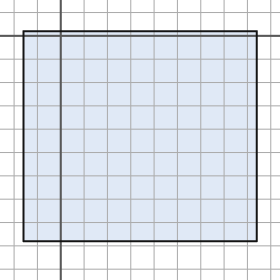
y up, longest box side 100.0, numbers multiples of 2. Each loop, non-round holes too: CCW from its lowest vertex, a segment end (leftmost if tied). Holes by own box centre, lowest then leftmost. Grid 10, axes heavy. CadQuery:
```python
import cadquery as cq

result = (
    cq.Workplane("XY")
    .moveTo(-16.0, -88.0)
    .lineTo(84.0, -88.0)
    .lineTo(84.0, 2.0)
    .lineTo(-16.0, 2.0)
    .close()
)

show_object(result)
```